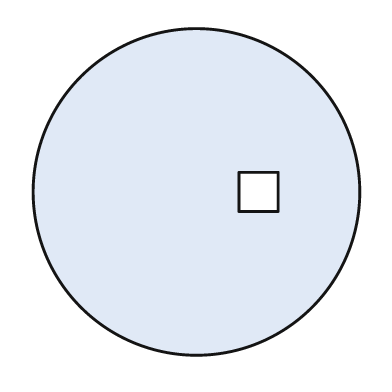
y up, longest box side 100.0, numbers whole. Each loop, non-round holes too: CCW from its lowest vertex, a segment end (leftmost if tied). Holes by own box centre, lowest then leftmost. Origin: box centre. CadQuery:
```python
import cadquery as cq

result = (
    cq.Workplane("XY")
    .moveTo(0.0, 0.0)
    .circle(50.0)
    .moveTo(13.0, -6.0)
    .lineTo(25.0, -6.0)
    .lineTo(25.0, 6.0)
    .lineTo(13.0, 6.0)
    .close()
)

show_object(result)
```